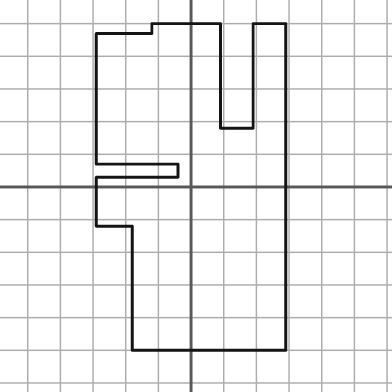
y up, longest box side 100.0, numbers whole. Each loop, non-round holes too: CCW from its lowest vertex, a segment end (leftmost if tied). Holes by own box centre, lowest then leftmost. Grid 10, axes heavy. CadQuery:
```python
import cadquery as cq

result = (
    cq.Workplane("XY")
    .moveTo(-18.0, -50.0)
    .lineTo(29.0, -50.0)
    .lineTo(29.0, 50.0)
    .lineTo(19.0, 50.0)
    .lineTo(19.0, 18.0)
    .lineTo(9.0, 18.0)
    .lineTo(9.0, 50.0)
    .lineTo(-12.0, 50.0)
    .lineTo(-12.0, 47.0)
    .lineTo(-29.0, 47.0)
    .lineTo(-29.0, 7.0)
    .lineTo(-4.0, 7.0)
    .lineTo(-4.0, 3.0)
    .lineTo(-29.0, 3.0)
    .lineTo(-29.0, -12.0)
    .lineTo(-18.0, -12.0)
    .close()
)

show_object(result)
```